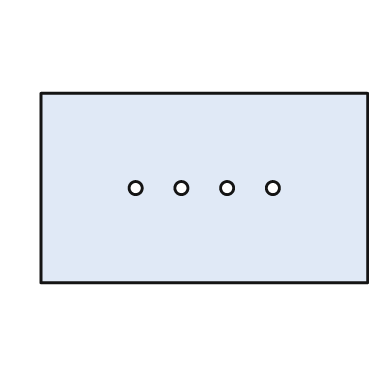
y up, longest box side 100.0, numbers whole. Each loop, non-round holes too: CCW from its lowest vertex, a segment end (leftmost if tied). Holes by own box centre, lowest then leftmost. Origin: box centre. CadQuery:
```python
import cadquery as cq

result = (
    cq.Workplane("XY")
    .moveTo(-50.0, -29.0)
    .lineTo(50.0, -29.0)
    .lineTo(50.0, 29.0)
    .lineTo(-50.0, 29.0)
    .close()
    .moveTo(-21.0, 0.0)
    .circle(2.0)
    .moveTo(-7.0, 0.0)
    .circle(2.0)
    .moveTo(7.0, 0.0)
    .circle(2.0)
    .moveTo(21.0, 0.0)
    .circle(2.0)
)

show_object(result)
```